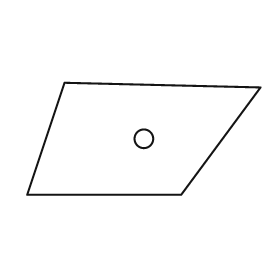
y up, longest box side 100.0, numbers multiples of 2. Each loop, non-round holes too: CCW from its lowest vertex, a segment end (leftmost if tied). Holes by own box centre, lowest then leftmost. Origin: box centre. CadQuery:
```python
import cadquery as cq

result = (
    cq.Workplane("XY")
    .moveTo(-50.0, -24.0)
    .lineTo(16.0, -24.0)
    .lineTo(50.0, 22.0)
    .lineTo(-34.0, 24.0)
    .close()
    .moveTo(0.0, 0.0)
    .circle(4.0)
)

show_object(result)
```